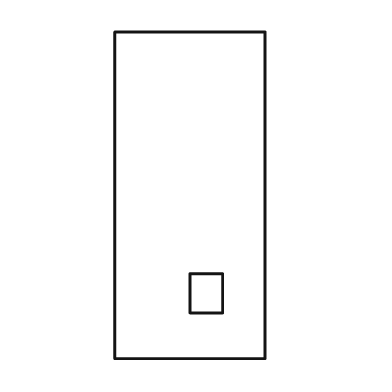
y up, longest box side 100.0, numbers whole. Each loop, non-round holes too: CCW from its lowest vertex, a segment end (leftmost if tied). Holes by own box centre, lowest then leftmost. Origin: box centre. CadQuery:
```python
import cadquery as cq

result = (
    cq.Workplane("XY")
    .moveTo(-23.0, -50.0)
    .lineTo(23.0, -50.0)
    .lineTo(23.0, 50.0)
    .lineTo(-23.0, 50.0)
    .close()
    .moveTo(0.0, -36.0)
    .lineTo(10.0, -36.0)
    .lineTo(10.0, -24.0)
    .lineTo(0.0, -24.0)
    .close()
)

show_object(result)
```